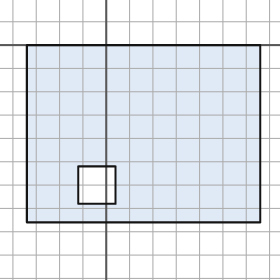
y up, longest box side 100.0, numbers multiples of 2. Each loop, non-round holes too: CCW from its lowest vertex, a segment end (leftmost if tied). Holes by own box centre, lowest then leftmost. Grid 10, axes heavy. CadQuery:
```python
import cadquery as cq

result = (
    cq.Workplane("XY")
    .moveTo(-34.0, -76.0)
    .lineTo(66.0, -76.0)
    .lineTo(66.0, 0.0)
    .lineTo(-34.0, 0.0)
    .close()
    .moveTo(-12.0, -68.0)
    .lineTo(4.0, -68.0)
    .lineTo(4.0, -52.0)
    .lineTo(-12.0, -52.0)
    .close()
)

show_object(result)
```